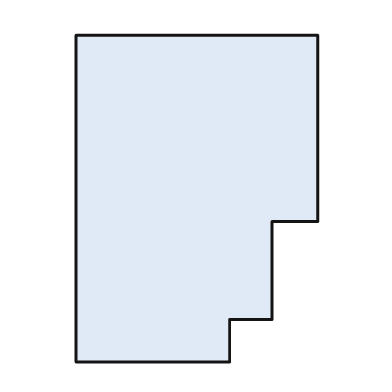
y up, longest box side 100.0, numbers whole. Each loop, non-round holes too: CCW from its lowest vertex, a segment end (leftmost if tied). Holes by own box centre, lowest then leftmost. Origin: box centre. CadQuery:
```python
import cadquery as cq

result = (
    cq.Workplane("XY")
    .moveTo(-37.0, -50.0)
    .lineTo(10.0, -50.0)
    .lineTo(10.0, -37.0)
    .lineTo(23.0, -37.0)
    .lineTo(23.0, -7.0)
    .lineTo(37.0, -7.0)
    .lineTo(37.0, 50.0)
    .lineTo(-37.0, 50.0)
    .close()
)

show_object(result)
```